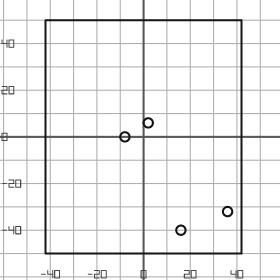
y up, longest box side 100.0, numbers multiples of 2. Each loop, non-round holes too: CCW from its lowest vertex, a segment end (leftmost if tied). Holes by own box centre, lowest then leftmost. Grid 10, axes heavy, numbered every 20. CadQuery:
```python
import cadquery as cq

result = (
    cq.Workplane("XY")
    .moveTo(-42.0, -50.0)
    .lineTo(42.0, -50.0)
    .lineTo(42.0, 50.0)
    .lineTo(-42.0, 50.0)
    .close()
    .moveTo(16.0, -40.0)
    .circle(2.0)
    .moveTo(36.0, -32.0)
    .circle(2.0)
    .moveTo(-8.0, 0.0)
    .circle(2.0)
    .moveTo(2.0, 6.0)
    .circle(2.0)
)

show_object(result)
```